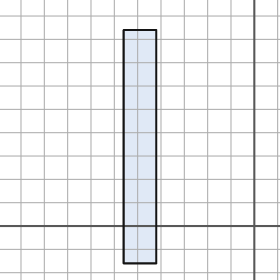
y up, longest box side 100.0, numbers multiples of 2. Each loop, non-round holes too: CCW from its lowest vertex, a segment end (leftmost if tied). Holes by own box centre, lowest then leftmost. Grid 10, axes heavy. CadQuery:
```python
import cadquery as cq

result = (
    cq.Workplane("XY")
    .moveTo(-56.0, -16.0)
    .lineTo(-42.0, -16.0)
    .lineTo(-42.0, 84.0)
    .lineTo(-56.0, 84.0)
    .close()
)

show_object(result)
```